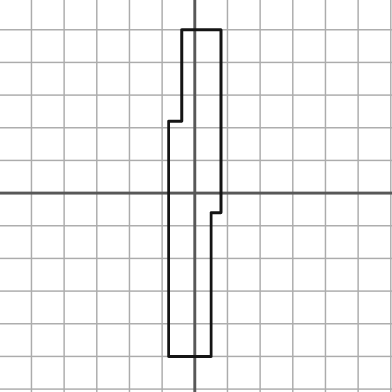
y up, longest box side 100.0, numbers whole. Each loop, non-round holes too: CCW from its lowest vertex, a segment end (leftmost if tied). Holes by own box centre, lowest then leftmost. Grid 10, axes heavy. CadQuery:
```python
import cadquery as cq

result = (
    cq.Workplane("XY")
    .moveTo(-8.0, -50.0)
    .lineTo(5.0, -50.0)
    .lineTo(5.0, -6.0)
    .lineTo(8.0, -6.0)
    .lineTo(8.0, 50.0)
    .lineTo(-4.0, 50.0)
    .lineTo(-4.0, 22.0)
    .lineTo(-8.0, 22.0)
    .close()
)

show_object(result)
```